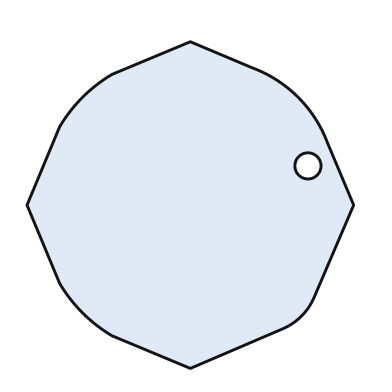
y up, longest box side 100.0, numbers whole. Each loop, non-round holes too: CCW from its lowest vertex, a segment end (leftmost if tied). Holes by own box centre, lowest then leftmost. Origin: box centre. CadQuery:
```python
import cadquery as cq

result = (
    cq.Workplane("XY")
    .moveTo(0.0, -50.0)
    .lineTo(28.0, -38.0)
    .threePointArc((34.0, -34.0), (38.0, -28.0))
    .lineTo(50.0, 0.0)
    .lineTo(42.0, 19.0)
    .threePointArc((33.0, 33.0), (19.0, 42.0))
    .lineTo(0.0, 50.0)
    .lineTo(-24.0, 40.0)
    .threePointArc((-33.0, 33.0), (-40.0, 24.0))
    .lineTo(-50.0, 0.0)
    .lineTo(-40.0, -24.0)
    .threePointArc((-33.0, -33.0), (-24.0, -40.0))
    .close()
    .moveTo(36.0, 12.0)
    .circle(4.0)
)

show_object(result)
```